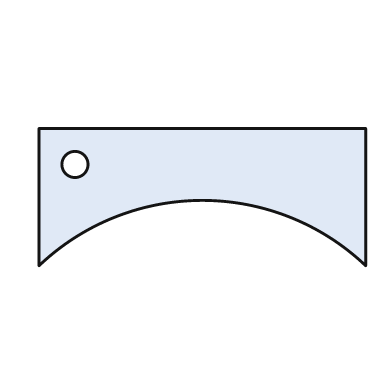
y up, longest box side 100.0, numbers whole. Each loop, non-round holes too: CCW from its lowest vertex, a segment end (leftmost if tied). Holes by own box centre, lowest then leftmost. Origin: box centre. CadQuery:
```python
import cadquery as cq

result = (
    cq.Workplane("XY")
    .moveTo(-50.0, -21.0)
    .threePointArc((0.0, -1.0), (50.0, -21.0))
    .lineTo(50.0, 21.0)
    .lineTo(-50.0, 21.0)
    .close()
    .moveTo(-39.0, 10.0)
    .circle(4.0)
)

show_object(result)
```